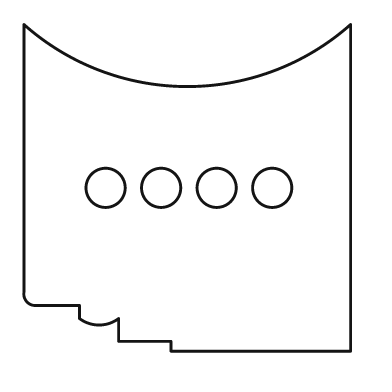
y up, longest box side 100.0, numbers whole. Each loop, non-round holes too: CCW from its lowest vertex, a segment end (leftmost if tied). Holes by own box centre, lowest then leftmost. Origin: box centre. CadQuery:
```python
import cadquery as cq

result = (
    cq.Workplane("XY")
    .moveTo(-5.0, -50.0)
    .lineTo(50.0, -50.0)
    .lineTo(50.0, 50.0)
    .threePointArc((0.0, 31.0), (-50.0, 50.0))
    .lineTo(-50.0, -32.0)
    .threePointArc((-49.0, -35.0), (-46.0, -36.0))
    .lineTo(-33.0, -36.0)
    .lineTo(-33.0, -40.0)
    .threePointArc((-27.0, -42.0), (-21.0, -40.0))
    .lineTo(-21.0, -47.0)
    .lineTo(-5.0, -47.0)
    .close()
    .moveTo(-25.0, 0.0)
    .circle(6.0)
    .moveTo(-8.0, 0.0)
    .circle(6.0)
    .moveTo(9.0, 0.0)
    .circle(6.0)
    .moveTo(26.0, 0.0)
    .circle(6.0)
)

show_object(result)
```